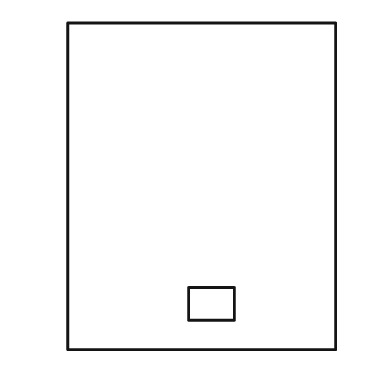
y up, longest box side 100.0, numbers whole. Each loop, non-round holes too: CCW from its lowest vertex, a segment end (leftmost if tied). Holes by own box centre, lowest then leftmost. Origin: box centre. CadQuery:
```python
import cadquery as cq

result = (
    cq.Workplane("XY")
    .moveTo(-41.0, -50.0)
    .lineTo(41.0, -50.0)
    .lineTo(41.0, 50.0)
    .lineTo(-41.0, 50.0)
    .close()
    .moveTo(-4.0, -41.0)
    .lineTo(10.0, -41.0)
    .lineTo(10.0, -31.0)
    .lineTo(-4.0, -31.0)
    .close()
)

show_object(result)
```